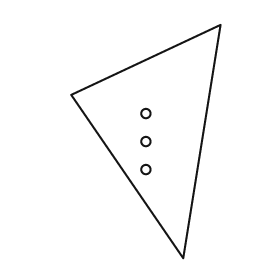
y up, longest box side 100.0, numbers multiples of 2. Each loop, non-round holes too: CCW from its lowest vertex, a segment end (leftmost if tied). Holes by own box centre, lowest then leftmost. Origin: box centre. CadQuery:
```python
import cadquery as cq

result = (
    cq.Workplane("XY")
    .moveTo(16.0, -50.0)
    .lineTo(32.0, 50.0)
    .lineTo(-32.0, 20.0)
    .close()
    .moveTo(0.0, -12.0)
    .circle(2.0)
    .moveTo(0.0, 0.0)
    .circle(2.0)
    .moveTo(0.0, 12.0)
    .circle(2.0)
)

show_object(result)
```